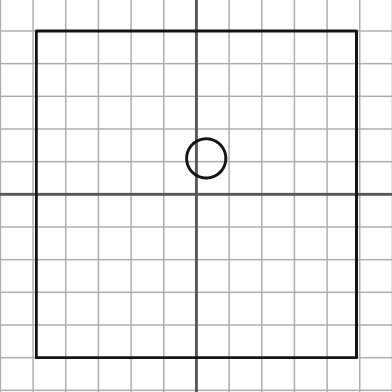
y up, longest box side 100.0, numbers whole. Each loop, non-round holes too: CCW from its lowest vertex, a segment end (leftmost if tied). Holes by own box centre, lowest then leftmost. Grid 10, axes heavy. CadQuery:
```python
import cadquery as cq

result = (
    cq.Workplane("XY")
    .moveTo(-49.0, -50.0)
    .lineTo(49.0, -50.0)
    .lineTo(49.0, 50.0)
    .lineTo(-49.0, 50.0)
    .close()
    .moveTo(3.0, 11.0)
    .circle(6.0)
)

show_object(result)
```